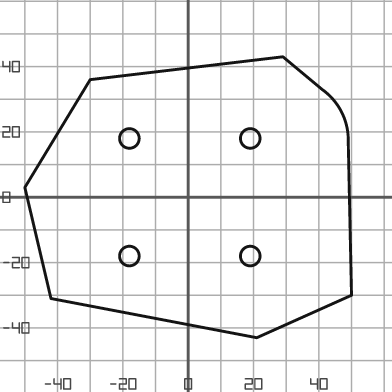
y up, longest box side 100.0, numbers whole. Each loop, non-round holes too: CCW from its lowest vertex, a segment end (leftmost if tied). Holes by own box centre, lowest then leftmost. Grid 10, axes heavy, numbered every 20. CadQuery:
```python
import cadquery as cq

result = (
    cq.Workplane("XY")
    .moveTo(21.0, -43.0)
    .lineTo(50.0, -30.0)
    .lineTo(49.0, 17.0)
    .threePointArc((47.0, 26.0), (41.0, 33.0))
    .lineTo(29.0, 43.0)
    .lineTo(-30.0, 36.0)
    .lineTo(-50.0, 3.0)
    .lineTo(-42.0, -31.0)
    .close()
    .moveTo(-18.0, -18.0)
    .circle(3.0)
    .moveTo(19.0, -18.0)
    .circle(3.0)
    .moveTo(-18.0, 18.0)
    .circle(3.0)
    .moveTo(19.0, 18.0)
    .circle(3.0)
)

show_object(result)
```